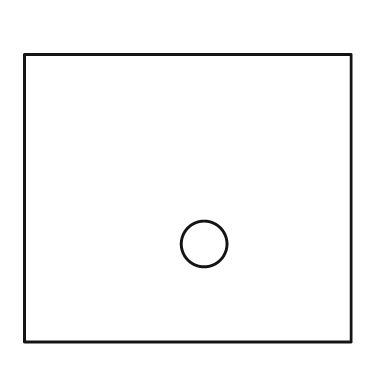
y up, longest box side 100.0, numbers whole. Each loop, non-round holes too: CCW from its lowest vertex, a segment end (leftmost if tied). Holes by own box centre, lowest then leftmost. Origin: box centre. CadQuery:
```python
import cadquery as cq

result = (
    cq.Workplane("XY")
    .moveTo(-50.0, -44.0)
    .lineTo(50.0, -44.0)
    .lineTo(50.0, 44.0)
    .lineTo(-50.0, 44.0)
    .close()
    .moveTo(5.0, -14.0)
    .circle(7.0)
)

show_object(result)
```